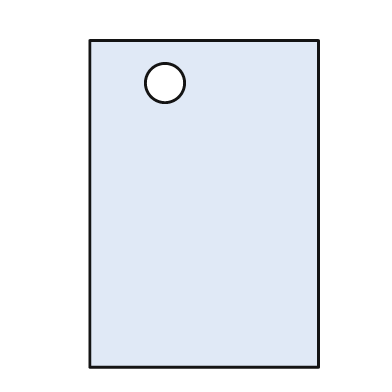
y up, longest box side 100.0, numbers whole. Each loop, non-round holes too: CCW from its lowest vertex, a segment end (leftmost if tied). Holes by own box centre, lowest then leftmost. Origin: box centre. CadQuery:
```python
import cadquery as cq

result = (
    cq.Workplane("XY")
    .moveTo(-35.0, -50.0)
    .lineTo(35.0, -50.0)
    .lineTo(35.0, 50.0)
    .lineTo(-35.0, 50.0)
    .close()
    .moveTo(-12.0, 37.0)
    .circle(6.0)
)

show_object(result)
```